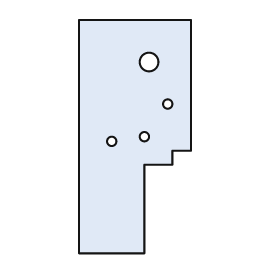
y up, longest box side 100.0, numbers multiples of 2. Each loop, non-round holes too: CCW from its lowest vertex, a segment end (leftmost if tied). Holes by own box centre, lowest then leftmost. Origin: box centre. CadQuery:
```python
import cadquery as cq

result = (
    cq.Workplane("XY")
    .moveTo(-24.0, -50.0)
    .lineTo(4.0, -50.0)
    .lineTo(4.0, -12.0)
    .lineTo(16.0, -12.0)
    .lineTo(16.0, -6.0)
    .lineTo(24.0, -6.0)
    .lineTo(24.0, 50.0)
    .lineTo(-24.0, 50.0)
    .close()
    .moveTo(-10.0, -2.0)
    .circle(2.0)
    .moveTo(4.0, 0.0)
    .circle(2.0)
    .moveTo(14.0, 14.0)
    .circle(2.0)
    .moveTo(6.0, 32.0)
    .circle(4.0)
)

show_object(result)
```